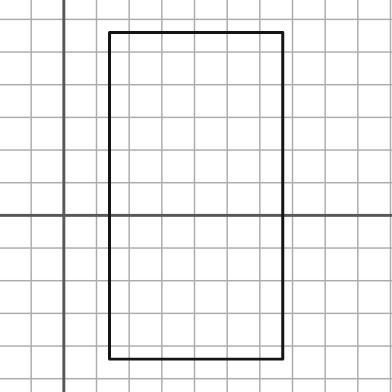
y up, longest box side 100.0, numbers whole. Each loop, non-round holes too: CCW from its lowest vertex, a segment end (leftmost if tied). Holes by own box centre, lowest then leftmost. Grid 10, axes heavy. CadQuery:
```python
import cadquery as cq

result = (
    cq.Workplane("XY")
    .moveTo(14.0, -44.0)
    .lineTo(67.0, -44.0)
    .lineTo(67.0, 56.0)
    .lineTo(14.0, 56.0)
    .close()
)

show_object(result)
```